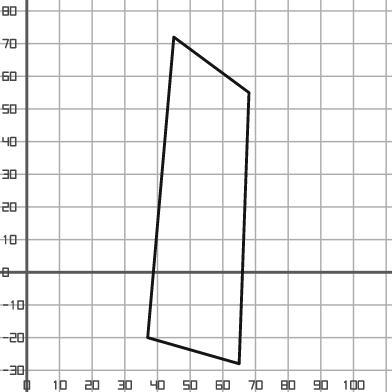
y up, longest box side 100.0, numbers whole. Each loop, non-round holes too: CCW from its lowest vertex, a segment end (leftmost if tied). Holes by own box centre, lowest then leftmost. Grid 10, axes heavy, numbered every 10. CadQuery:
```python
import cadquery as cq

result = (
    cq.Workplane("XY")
    .moveTo(65.0, -28.0)
    .lineTo(68.0, 55.0)
    .lineTo(45.0, 72.0)
    .lineTo(37.0, -20.0)
    .close()
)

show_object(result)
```